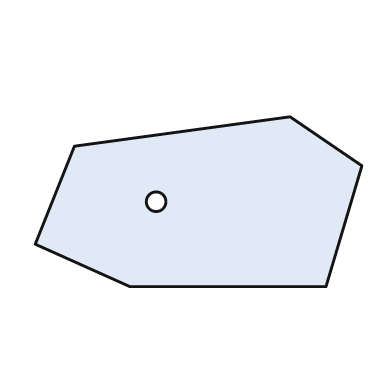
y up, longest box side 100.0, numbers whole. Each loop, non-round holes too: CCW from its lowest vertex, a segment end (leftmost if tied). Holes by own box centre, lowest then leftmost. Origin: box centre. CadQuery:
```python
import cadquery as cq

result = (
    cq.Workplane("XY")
    .moveTo(-21.0, -26.0)
    .lineTo(39.0, -26.0)
    .lineTo(50.0, 11.0)
    .lineTo(28.0, 26.0)
    .lineTo(-38.0, 17.0)
    .lineTo(-50.0, -13.0)
    .close()
    .moveTo(-13.0, 0.0)
    .circle(3.0)
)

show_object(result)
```